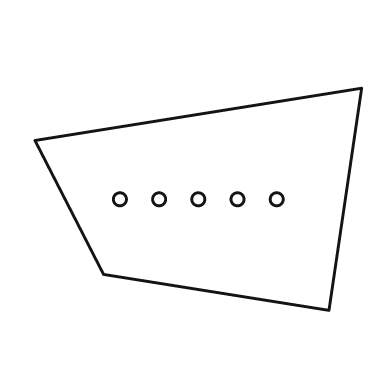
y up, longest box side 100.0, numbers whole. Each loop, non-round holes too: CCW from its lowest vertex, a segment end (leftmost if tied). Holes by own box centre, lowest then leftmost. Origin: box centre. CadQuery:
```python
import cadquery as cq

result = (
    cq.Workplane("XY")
    .moveTo(40.0, -34.0)
    .lineTo(50.0, 34.0)
    .lineTo(-50.0, 18.0)
    .lineTo(-29.0, -23.0)
    .close()
    .moveTo(-24.0, 0.0)
    .circle(2.0)
    .moveTo(-12.0, 0.0)
    .circle(2.0)
    .moveTo(0.0, 0.0)
    .circle(2.0)
    .moveTo(12.0, 0.0)
    .circle(2.0)
    .moveTo(24.0, 0.0)
    .circle(2.0)
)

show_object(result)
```